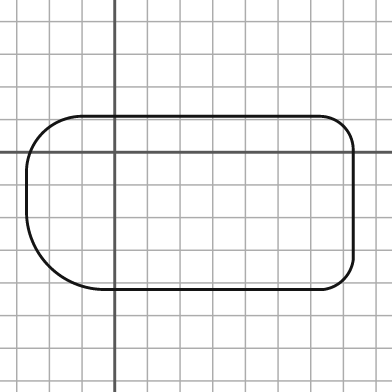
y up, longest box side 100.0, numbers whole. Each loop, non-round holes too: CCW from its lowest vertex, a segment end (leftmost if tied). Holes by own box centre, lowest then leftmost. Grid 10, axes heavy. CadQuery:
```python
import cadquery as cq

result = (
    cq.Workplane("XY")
    .moveTo(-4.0, -42.0)
    .lineTo(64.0, -42.0)
    .threePointArc((70.0, -39.0), (73.0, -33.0))
    .lineTo(73.0, 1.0)
    .threePointArc((70.0, 8.0), (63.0, 11.0))
    .lineTo(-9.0, 11.0)
    .threePointArc((-22.0, 6.0), (-27.0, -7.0))
    .lineTo(-27.0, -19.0)
    .threePointArc((-20.0, -35.0), (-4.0, -42.0))
    .close()
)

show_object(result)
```